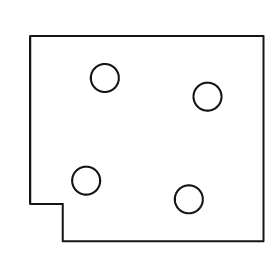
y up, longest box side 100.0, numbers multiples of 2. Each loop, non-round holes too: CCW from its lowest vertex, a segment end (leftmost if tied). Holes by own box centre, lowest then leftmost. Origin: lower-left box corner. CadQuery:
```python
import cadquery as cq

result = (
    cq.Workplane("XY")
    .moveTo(14.0, 0.0)
    .lineTo(100.0, 0.0)
    .lineTo(100.0, 88.0)
    .lineTo(0.0, 88.0)
    .lineTo(0.0, 16.0)
    .lineTo(14.0, 16.0)
    .close()
    .moveTo(68.0, 18.0)
    .circle(6.0)
    .moveTo(24.0, 26.0)
    .circle(6.0)
    .moveTo(76.0, 62.0)
    .circle(6.0)
    .moveTo(32.0, 70.0)
    .circle(6.0)
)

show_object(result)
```